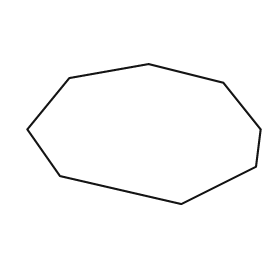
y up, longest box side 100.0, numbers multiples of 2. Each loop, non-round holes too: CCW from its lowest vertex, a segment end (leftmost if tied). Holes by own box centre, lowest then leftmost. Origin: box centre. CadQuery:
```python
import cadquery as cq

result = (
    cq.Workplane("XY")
    .moveTo(16.0, -30.0)
    .lineTo(48.0, -14.0)
    .lineTo(50.0, 2.0)
    .lineTo(34.0, 22.0)
    .lineTo(2.0, 30.0)
    .lineTo(-32.0, 24.0)
    .lineTo(-50.0, 2.0)
    .lineTo(-36.0, -18.0)
    .close()
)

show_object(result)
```